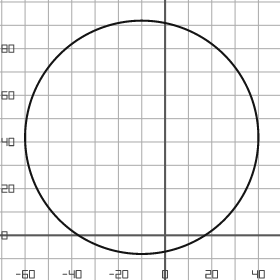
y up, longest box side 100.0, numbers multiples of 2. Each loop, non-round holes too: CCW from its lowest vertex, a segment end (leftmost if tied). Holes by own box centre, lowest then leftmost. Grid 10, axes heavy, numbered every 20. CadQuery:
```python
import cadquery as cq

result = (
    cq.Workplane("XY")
    .moveTo(-10.0, 42.0)
    .circle(50.0)
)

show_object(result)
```